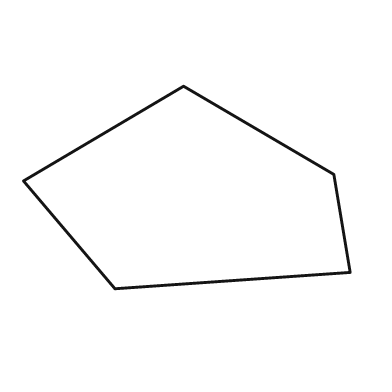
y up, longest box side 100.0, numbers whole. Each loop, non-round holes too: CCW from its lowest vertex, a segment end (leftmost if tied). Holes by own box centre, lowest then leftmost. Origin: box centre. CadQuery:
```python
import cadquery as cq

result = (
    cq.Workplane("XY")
    .moveTo(-22.0, -31.0)
    .lineTo(50.0, -26.0)
    .lineTo(45.0, 4.0)
    .lineTo(-1.0, 31.0)
    .lineTo(-50.0, 2.0)
    .close()
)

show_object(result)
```